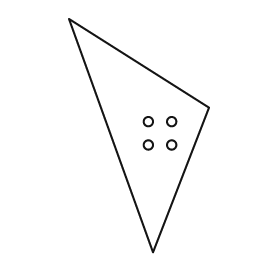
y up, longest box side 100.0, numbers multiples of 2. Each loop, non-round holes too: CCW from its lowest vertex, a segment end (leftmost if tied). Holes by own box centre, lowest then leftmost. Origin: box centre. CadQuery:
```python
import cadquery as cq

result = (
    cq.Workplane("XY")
    .moveTo(6.0, -50.0)
    .lineTo(30.0, 12.0)
    .lineTo(-30.0, 50.0)
    .close()
    .moveTo(4.0, -4.0)
    .circle(2.0)
    .moveTo(14.0, -4.0)
    .circle(2.0)
    .moveTo(4.0, 6.0)
    .circle(2.0)
    .moveTo(14.0, 6.0)
    .circle(2.0)
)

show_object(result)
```